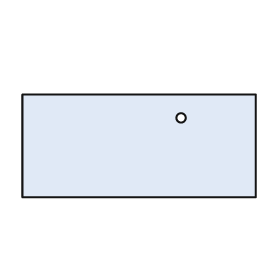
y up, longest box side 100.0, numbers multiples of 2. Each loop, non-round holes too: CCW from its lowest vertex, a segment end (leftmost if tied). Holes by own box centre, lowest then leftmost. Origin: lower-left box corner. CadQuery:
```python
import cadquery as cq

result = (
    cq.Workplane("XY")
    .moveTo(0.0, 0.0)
    .lineTo(100.0, 0.0)
    .lineTo(100.0, 44.0)
    .lineTo(0.0, 44.0)
    .close()
    .moveTo(68.0, 34.0)
    .circle(2.0)
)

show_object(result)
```